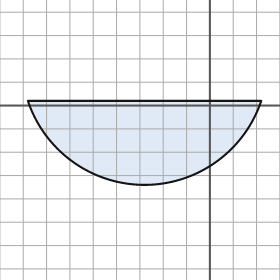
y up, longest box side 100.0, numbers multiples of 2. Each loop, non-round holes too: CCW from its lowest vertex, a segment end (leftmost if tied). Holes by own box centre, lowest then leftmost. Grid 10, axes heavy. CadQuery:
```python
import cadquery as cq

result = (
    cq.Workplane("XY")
    .moveTo(-78.0, 2.0)
    .threePointArc((-28.0, -34.0), (22.0, 2.0))
    .close()
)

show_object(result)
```